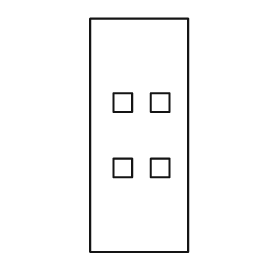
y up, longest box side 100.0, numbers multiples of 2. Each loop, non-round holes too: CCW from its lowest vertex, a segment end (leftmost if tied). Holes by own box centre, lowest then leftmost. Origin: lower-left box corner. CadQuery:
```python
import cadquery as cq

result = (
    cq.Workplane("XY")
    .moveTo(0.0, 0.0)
    .lineTo(42.0, 0.0)
    .lineTo(42.0, 100.0)
    .lineTo(0.0, 100.0)
    .close()
    .moveTo(10.0, 32.0)
    .lineTo(18.0, 32.0)
    .lineTo(18.0, 40.0)
    .lineTo(10.0, 40.0)
    .close()
    .moveTo(26.0, 32.0)
    .lineTo(34.0, 32.0)
    .lineTo(34.0, 40.0)
    .lineTo(26.0, 40.0)
    .close()
    .moveTo(10.0, 60.0)
    .lineTo(18.0, 60.0)
    .lineTo(18.0, 68.0)
    .lineTo(10.0, 68.0)
    .close()
    .moveTo(26.0, 60.0)
    .lineTo(34.0, 60.0)
    .lineTo(34.0, 68.0)
    .lineTo(26.0, 68.0)
    .close()
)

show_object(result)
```